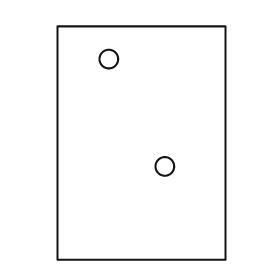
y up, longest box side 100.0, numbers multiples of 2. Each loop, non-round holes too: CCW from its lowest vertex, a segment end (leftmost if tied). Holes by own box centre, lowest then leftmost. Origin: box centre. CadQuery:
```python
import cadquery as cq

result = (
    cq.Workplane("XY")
    .moveTo(-36.0, -50.0)
    .lineTo(36.0, -50.0)
    .lineTo(36.0, 50.0)
    .lineTo(-36.0, 50.0)
    .close()
    .moveTo(10.0, -10.0)
    .circle(4.0)
    .moveTo(-14.0, 36.0)
    .circle(4.0)
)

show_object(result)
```